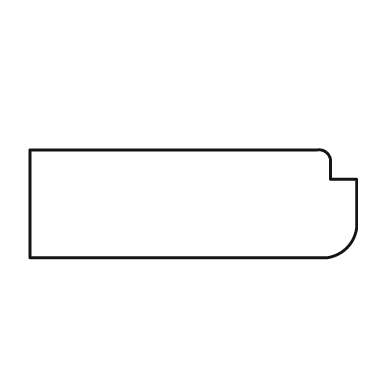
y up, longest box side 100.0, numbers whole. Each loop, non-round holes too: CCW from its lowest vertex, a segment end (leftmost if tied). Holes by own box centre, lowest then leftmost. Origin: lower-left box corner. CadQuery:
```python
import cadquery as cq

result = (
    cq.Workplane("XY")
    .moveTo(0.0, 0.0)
    .lineTo(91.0, 0.0)
    .threePointArc((97.0, 3.0), (100.0, 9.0))
    .lineTo(100.0, 24.0)
    .lineTo(92.0, 24.0)
    .lineTo(92.0, 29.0)
    .threePointArc((91.0, 32.0), (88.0, 33.0))
    .lineTo(0.0, 33.0)
    .close()
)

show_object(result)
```